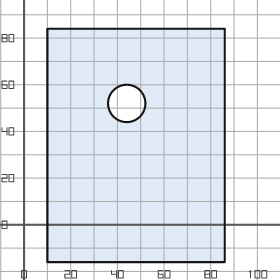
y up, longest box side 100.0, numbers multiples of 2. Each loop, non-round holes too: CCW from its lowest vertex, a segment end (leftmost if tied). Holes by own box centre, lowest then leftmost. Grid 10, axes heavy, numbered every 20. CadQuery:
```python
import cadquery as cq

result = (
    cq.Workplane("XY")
    .moveTo(10.0, -16.0)
    .lineTo(86.0, -16.0)
    .lineTo(86.0, 84.0)
    .lineTo(10.0, 84.0)
    .close()
    .moveTo(44.0, 52.0)
    .circle(8.0)
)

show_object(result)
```